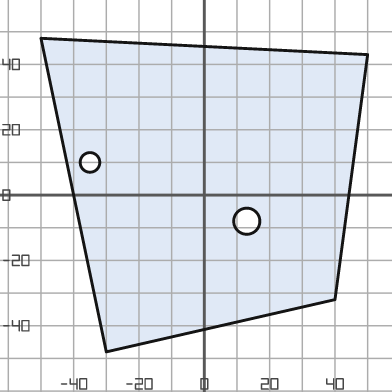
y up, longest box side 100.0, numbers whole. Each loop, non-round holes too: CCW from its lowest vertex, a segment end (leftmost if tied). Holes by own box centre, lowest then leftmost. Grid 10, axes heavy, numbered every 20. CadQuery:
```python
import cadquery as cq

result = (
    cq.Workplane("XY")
    .moveTo(-30.0, -48.0)
    .lineTo(40.0, -32.0)
    .lineTo(50.0, 43.0)
    .lineTo(-50.0, 48.0)
    .close()
    .moveTo(13.0, -8.0)
    .circle(4.0)
    .moveTo(-35.0, 10.0)
    .circle(3.0)
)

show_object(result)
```